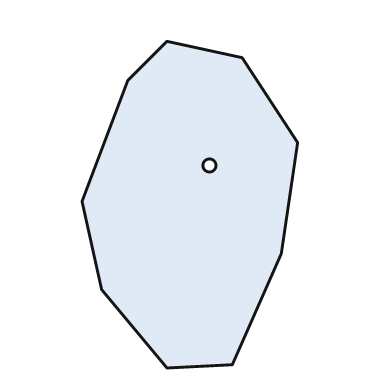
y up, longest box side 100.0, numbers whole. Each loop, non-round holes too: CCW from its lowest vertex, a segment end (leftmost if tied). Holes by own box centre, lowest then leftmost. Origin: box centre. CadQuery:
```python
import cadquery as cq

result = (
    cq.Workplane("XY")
    .moveTo(-7.0, -50.0)
    .lineTo(13.0, -49.0)
    .lineTo(28.0, -15.0)
    .lineTo(33.0, 19.0)
    .lineTo(16.0, 45.0)
    .lineTo(-7.0, 50.0)
    .lineTo(-19.0, 38.0)
    .lineTo(-33.0, 1.0)
    .lineTo(-27.0, -26.0)
    .close()
    .moveTo(6.0, 12.0)
    .circle(2.0)
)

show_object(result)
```